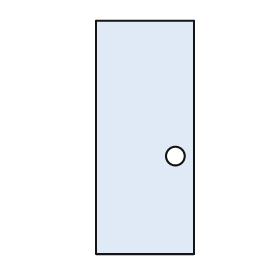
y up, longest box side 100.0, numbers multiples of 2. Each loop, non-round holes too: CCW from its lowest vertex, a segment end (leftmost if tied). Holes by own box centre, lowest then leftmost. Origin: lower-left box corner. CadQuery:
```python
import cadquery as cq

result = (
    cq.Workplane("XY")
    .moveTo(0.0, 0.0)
    .lineTo(42.0, 0.0)
    .lineTo(42.0, 100.0)
    .lineTo(0.0, 100.0)
    .close()
    .moveTo(34.0, 42.0)
    .circle(4.0)
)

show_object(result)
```